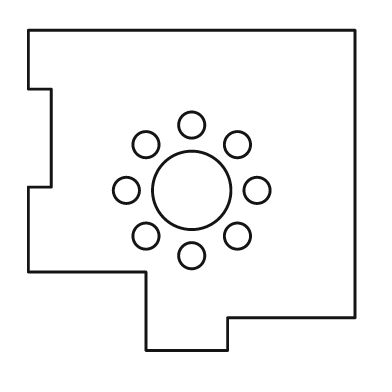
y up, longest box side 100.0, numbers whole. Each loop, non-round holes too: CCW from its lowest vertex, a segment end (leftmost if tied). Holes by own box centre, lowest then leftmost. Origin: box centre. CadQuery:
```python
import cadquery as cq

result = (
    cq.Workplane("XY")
    .moveTo(-14.0, -49.0)
    .lineTo(11.0, -49.0)
    .lineTo(11.0, -39.0)
    .lineTo(50.0, -39.0)
    .lineTo(50.0, 49.0)
    .lineTo(-50.0, 49.0)
    .lineTo(-50.0, 31.0)
    .lineTo(-43.0, 31.0)
    .lineTo(-43.0, 1.0)
    .lineTo(-50.0, 1.0)
    .lineTo(-50.0, -25.0)
    .lineTo(-14.0, -25.0)
    .close()
    .moveTo(0.0, -20.0)
    .circle(4.0)
    .moveTo(-14.0, -14.0)
    .circle(4.0)
    .moveTo(14.0, -14.0)
    .circle(4.0)
    .moveTo(-20.0, 0.0)
    .circle(4.0)
    .moveTo(0.0, 0.0)
    .circle(12.0)
    .moveTo(20.0, 0.0)
    .circle(4.0)
    .moveTo(-14.0, 14.0)
    .circle(4.0)
    .moveTo(14.0, 14.0)
    .circle(4.0)
    .moveTo(0.0, 20.0)
    .circle(4.0)
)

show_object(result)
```